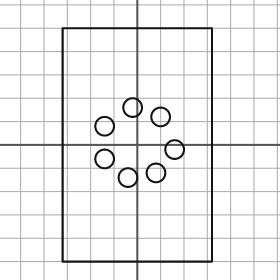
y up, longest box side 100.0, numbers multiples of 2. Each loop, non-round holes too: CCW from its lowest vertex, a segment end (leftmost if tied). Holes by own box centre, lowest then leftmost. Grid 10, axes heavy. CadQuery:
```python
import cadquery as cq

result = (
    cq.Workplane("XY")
    .moveTo(-32.0, -50.0)
    .lineTo(32.0, -50.0)
    .lineTo(32.0, 50.0)
    .lineTo(-32.0, 50.0)
    .close()
    .moveTo(-4.0, -14.0)
    .circle(4.0)
    .moveTo(8.0, -12.0)
    .circle(4.0)
    .moveTo(-14.0, -6.0)
    .circle(4.0)
    .moveTo(16.0, -2.0)
    .circle(4.0)
    .moveTo(-14.0, 8.0)
    .circle(4.0)
    .moveTo(10.0, 12.0)
    .circle(4.0)
    .moveTo(-2.0, 16.0)
    .circle(4.0)
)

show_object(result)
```